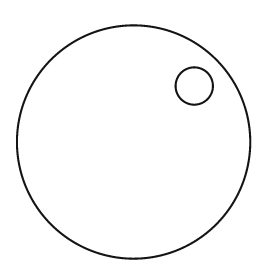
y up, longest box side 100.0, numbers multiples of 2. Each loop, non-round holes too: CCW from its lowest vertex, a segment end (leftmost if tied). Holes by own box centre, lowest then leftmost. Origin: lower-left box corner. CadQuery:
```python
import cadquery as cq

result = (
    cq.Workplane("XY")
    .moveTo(50.0, 50.0)
    .circle(50.0)
    .moveTo(76.0, 74.0)
    .circle(8.0)
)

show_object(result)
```